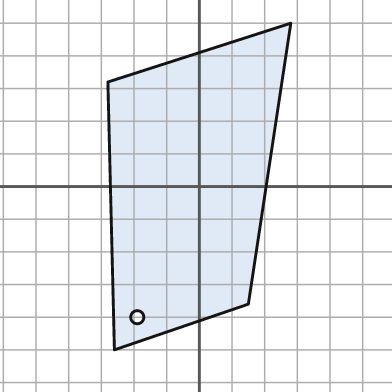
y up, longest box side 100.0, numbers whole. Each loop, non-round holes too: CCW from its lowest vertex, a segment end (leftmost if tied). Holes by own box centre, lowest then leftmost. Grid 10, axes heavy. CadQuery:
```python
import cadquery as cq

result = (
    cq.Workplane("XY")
    .moveTo(-26.0, -50.0)
    .lineTo(15.0, -36.0)
    .lineTo(28.0, 50.0)
    .lineTo(-28.0, 32.0)
    .close()
    .moveTo(-19.0, -40.0)
    .circle(2.0)
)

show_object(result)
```